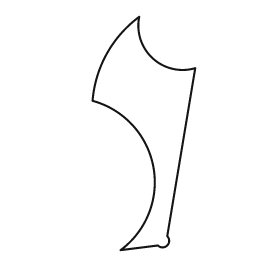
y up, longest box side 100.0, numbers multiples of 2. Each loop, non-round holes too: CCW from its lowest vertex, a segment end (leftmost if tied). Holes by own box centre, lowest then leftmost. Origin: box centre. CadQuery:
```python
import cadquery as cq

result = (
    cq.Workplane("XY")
    .moveTo(-10.0, -50.0)
    .lineTo(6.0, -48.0)
    .threePointArc((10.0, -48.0), (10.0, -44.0))
    .lineTo(22.0, 28.0)
    .threePointArc((4.0, 32.0), (-2.0, 50.0))
    .threePointArc((-16.0, 34.0), (-22.0, 14.0))
    .threePointArc((4.0, -14.0), (-10.0, -50.0))
    .close()
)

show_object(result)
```